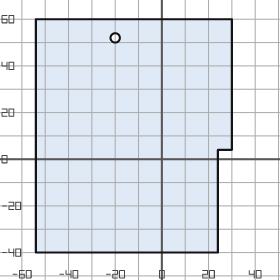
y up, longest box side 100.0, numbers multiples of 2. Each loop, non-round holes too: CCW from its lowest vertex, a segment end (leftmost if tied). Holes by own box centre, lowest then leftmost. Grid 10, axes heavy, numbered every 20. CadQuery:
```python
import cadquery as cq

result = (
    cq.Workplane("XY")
    .moveTo(-54.0, -40.0)
    .lineTo(24.0, -40.0)
    .lineTo(24.0, 4.0)
    .lineTo(30.0, 4.0)
    .lineTo(30.0, 60.0)
    .lineTo(-54.0, 60.0)
    .close()
    .moveTo(-20.0, 52.0)
    .circle(2.0)
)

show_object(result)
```